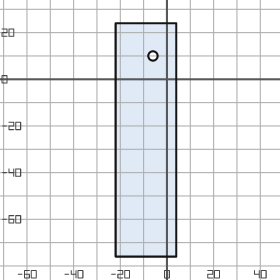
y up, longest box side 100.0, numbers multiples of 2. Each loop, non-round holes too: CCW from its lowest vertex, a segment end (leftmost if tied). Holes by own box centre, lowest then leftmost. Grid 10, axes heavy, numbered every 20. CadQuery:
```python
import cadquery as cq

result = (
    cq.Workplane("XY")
    .moveTo(-22.0, -76.0)
    .lineTo(4.0, -76.0)
    .lineTo(4.0, 24.0)
    .lineTo(-22.0, 24.0)
    .close()
    .moveTo(-6.0, 10.0)
    .circle(2.0)
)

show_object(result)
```